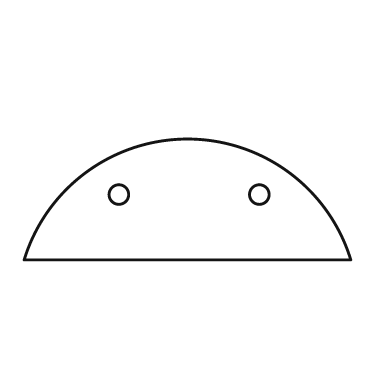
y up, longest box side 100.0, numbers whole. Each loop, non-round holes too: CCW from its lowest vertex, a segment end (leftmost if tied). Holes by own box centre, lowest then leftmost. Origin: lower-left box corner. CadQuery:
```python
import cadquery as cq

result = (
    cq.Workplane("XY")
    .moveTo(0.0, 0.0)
    .lineTo(100.0, 0.0)
    .threePointArc((50.0, 37.0), (0.0, 0.0))
    .close()
    .moveTo(29.0, 20.0)
    .circle(3.0)
    .moveTo(72.0, 20.0)
    .circle(3.0)
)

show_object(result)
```